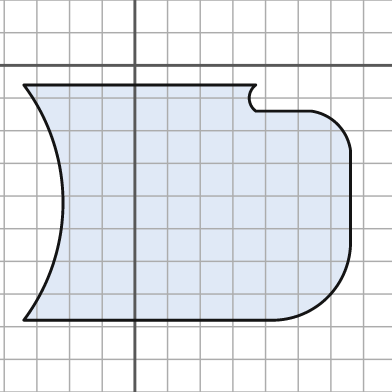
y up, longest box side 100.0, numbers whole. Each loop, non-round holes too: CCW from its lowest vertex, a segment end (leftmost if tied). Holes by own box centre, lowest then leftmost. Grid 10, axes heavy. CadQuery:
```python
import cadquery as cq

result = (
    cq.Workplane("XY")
    .moveTo(-34.0, -78.0)
    .lineTo(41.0, -78.0)
    .threePointArc((59.0, -71.0), (66.0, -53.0))
    .lineTo(66.0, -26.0)
    .threePointArc((62.0, -18.0), (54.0, -14.0))
    .lineTo(37.0, -14.0)
    .threePointArc((35.0, -10.0), (37.0, -6.0))
    .lineTo(-34.0, -6.0)
    .threePointArc((-22.0, -42.0), (-34.0, -78.0))
    .close()
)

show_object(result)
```